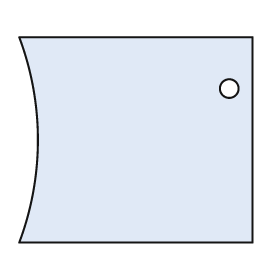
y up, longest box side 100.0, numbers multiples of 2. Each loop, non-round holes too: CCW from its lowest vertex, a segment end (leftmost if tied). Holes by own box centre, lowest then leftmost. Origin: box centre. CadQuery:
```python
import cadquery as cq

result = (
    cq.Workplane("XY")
    .moveTo(-50.0, -44.0)
    .lineTo(50.0, -44.0)
    .lineTo(50.0, 44.0)
    .lineTo(-50.0, 44.0)
    .threePointArc((-42.0, 0.0), (-50.0, -44.0))
    .close()
    .moveTo(40.0, 22.0)
    .circle(4.0)
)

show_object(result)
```